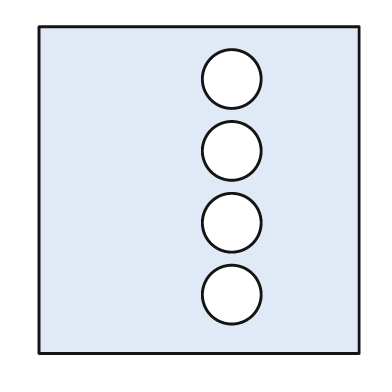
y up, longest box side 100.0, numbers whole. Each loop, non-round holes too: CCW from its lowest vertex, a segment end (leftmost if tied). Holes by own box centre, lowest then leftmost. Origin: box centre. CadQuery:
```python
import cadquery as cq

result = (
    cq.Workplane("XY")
    .moveTo(-49.0, -50.0)
    .lineTo(49.0, -50.0)
    .lineTo(49.0, 50.0)
    .lineTo(-49.0, 50.0)
    .close()
    .moveTo(10.0, -32.0)
    .circle(9.0)
    .moveTo(10.0, -10.0)
    .circle(9.0)
    .moveTo(10.0, 12.0)
    .circle(9.0)
    .moveTo(10.0, 34.0)
    .circle(9.0)
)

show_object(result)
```